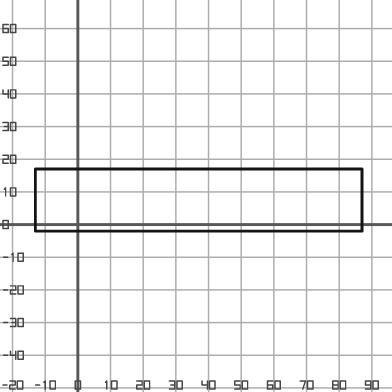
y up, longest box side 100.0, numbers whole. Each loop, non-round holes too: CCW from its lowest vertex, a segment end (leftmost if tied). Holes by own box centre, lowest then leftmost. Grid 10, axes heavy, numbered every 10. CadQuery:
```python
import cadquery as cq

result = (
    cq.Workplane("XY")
    .moveTo(-13.0, -2.0)
    .lineTo(87.0, -2.0)
    .lineTo(87.0, 17.0)
    .lineTo(-13.0, 17.0)
    .close()
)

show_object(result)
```